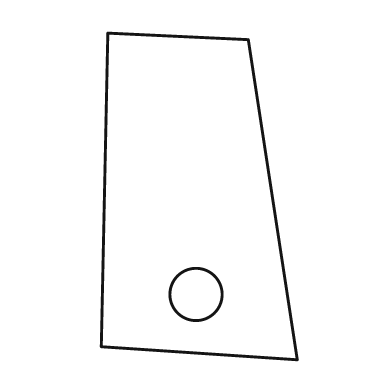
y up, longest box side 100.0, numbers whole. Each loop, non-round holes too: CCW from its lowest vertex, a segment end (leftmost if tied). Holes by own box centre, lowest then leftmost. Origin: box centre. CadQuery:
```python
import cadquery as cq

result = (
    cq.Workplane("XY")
    .moveTo(30.0, -50.0)
    .lineTo(15.0, 48.0)
    .lineTo(-28.0, 50.0)
    .lineTo(-30.0, -46.0)
    .close()
    .moveTo(-1.0, -30.0)
    .circle(8.0)
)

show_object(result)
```